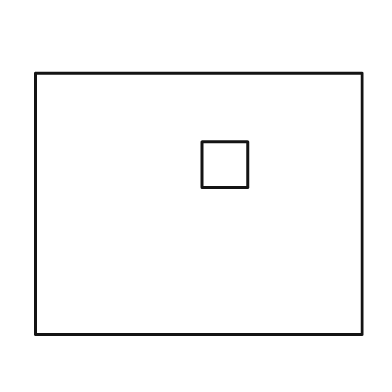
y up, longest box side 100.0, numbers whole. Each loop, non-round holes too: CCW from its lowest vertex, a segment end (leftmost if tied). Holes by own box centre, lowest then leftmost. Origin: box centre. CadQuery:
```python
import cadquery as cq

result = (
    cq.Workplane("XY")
    .moveTo(-50.0, -40.0)
    .lineTo(50.0, -40.0)
    .lineTo(50.0, 40.0)
    .lineTo(-50.0, 40.0)
    .close()
    .moveTo(1.0, 5.0)
    .lineTo(15.0, 5.0)
    .lineTo(15.0, 19.0)
    .lineTo(1.0, 19.0)
    .close()
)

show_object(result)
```